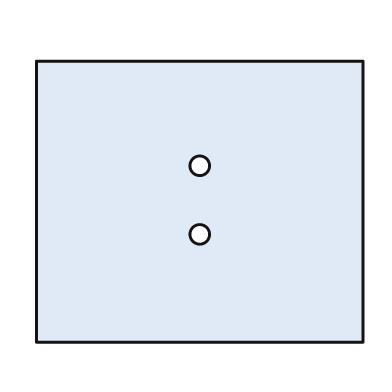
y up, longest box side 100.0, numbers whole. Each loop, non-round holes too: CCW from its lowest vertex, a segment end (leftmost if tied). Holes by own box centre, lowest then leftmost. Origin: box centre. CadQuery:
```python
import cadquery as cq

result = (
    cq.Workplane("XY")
    .moveTo(-50.0, -43.0)
    .lineTo(50.0, -43.0)
    .lineTo(50.0, 43.0)
    .lineTo(-50.0, 43.0)
    .close()
    .moveTo(0.0, -10.0)
    .circle(3.0)
    .moveTo(0.0, 11.0)
    .circle(3.0)
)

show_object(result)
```